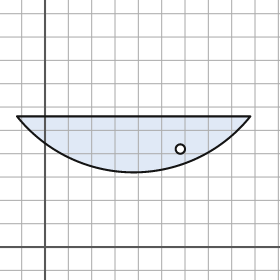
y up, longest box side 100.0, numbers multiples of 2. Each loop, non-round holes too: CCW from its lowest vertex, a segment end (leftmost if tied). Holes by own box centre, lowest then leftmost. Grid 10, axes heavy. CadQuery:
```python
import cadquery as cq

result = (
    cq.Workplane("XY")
    .moveTo(-12.0, 56.0)
    .threePointArc((38.0, 32.0), (88.0, 56.0))
    .close()
    .moveTo(58.0, 42.0)
    .circle(2.0)
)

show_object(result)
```